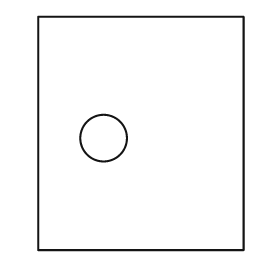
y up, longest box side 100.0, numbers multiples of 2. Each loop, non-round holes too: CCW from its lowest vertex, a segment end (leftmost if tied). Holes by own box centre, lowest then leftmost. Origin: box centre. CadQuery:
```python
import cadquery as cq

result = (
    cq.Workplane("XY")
    .moveTo(-44.0, -50.0)
    .lineTo(44.0, -50.0)
    .lineTo(44.0, 50.0)
    .lineTo(-44.0, 50.0)
    .close()
    .moveTo(-16.0, -2.0)
    .circle(10.0)
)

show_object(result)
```